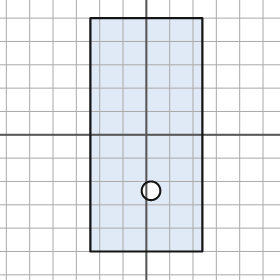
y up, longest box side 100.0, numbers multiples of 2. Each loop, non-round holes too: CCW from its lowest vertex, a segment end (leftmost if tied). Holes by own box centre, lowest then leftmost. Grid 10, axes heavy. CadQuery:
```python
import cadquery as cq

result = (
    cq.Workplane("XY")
    .moveTo(-24.0, -50.0)
    .lineTo(24.0, -50.0)
    .lineTo(24.0, 50.0)
    .lineTo(-24.0, 50.0)
    .close()
    .moveTo(2.0, -24.0)
    .circle(4.0)
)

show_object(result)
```